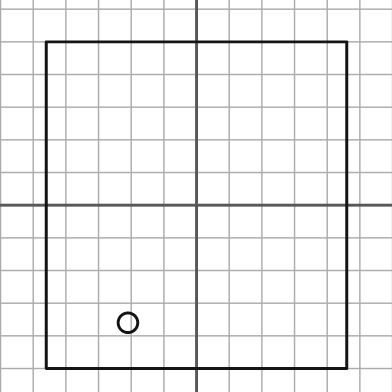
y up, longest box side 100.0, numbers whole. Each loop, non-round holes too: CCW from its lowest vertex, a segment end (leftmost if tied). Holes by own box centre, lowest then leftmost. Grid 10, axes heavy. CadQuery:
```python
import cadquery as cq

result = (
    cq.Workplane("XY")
    .moveTo(-46.0, -50.0)
    .lineTo(46.0, -50.0)
    .lineTo(46.0, 50.0)
    .lineTo(-46.0, 50.0)
    .close()
    .moveTo(-21.0, -36.0)
    .circle(3.0)
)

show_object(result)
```